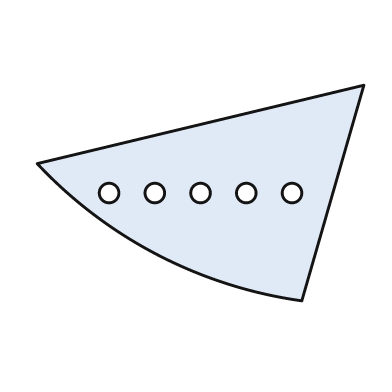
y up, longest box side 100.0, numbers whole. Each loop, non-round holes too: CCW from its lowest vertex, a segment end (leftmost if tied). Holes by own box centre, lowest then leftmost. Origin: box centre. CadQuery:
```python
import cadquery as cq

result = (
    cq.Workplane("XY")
    .moveTo(31.0, -33.0)
    .lineTo(50.0, 33.0)
    .lineTo(-50.0, 9.0)
    .threePointArc((-13.0, -19.0), (31.0, -33.0))
    .close()
    .moveTo(-28.0, 0.0)
    .circle(3.0)
    .moveTo(-14.0, 0.0)
    .circle(3.0)
    .moveTo(0.0, 0.0)
    .circle(3.0)
    .moveTo(14.0, 0.0)
    .circle(3.0)
    .moveTo(28.0, 0.0)
    .circle(3.0)
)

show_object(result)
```